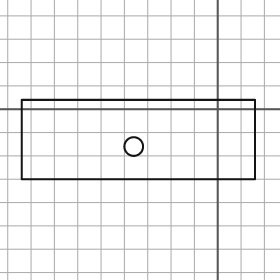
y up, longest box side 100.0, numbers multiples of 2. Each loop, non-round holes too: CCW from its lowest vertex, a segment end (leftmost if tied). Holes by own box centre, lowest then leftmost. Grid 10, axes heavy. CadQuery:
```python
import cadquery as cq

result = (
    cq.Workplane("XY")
    .moveTo(-84.0, -30.0)
    .lineTo(16.0, -30.0)
    .lineTo(16.0, 4.0)
    .lineTo(-84.0, 4.0)
    .close()
    .moveTo(-36.0, -16.0)
    .circle(4.0)
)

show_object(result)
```